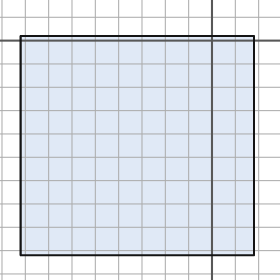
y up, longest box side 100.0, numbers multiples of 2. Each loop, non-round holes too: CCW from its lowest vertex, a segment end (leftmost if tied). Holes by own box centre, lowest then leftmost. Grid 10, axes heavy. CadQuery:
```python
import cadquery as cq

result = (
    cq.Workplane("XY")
    .moveTo(-82.0, -92.0)
    .lineTo(18.0, -92.0)
    .lineTo(18.0, 2.0)
    .lineTo(-82.0, 2.0)
    .close()
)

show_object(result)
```